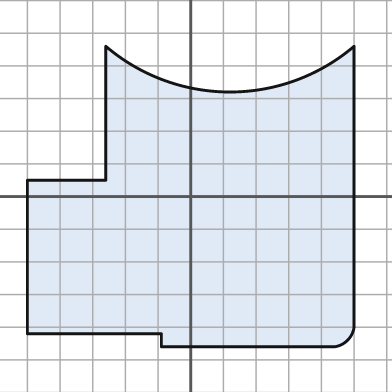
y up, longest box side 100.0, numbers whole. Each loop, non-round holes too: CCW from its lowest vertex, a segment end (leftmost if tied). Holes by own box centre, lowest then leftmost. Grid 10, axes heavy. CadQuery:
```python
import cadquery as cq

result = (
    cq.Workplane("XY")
    .moveTo(-9.0, -46.0)
    .lineTo(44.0, -46.0)
    .threePointArc((48.0, -44.0), (50.0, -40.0))
    .lineTo(50.0, 46.0)
    .threePointArc((12.0, 32.0), (-26.0, 46.0))
    .lineTo(-26.0, 5.0)
    .lineTo(-50.0, 5.0)
    .lineTo(-50.0, -42.0)
    .lineTo(-9.0, -42.0)
    .close()
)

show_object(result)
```